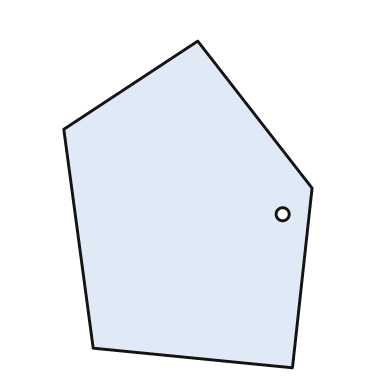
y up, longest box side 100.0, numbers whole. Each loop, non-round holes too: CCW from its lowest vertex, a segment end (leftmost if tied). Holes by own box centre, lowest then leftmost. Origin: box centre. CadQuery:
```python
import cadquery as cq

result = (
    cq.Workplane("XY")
    .moveTo(32.0, -50.0)
    .lineTo(38.0, 5.0)
    .lineTo(3.0, 50.0)
    .lineTo(-38.0, 23.0)
    .lineTo(-29.0, -44.0)
    .close()
    .moveTo(29.0, -3.0)
    .circle(2.0)
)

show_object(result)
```